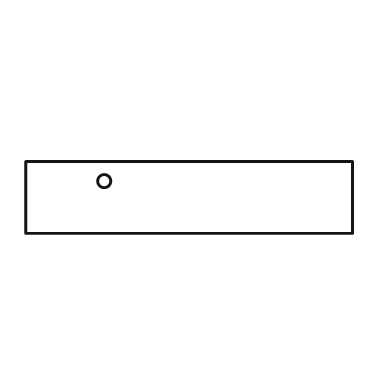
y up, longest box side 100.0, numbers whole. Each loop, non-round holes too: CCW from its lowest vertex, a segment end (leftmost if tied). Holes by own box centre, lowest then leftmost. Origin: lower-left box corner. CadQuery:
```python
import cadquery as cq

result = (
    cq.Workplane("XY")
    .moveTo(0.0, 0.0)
    .lineTo(100.0, 0.0)
    .lineTo(100.0, 22.0)
    .lineTo(0.0, 22.0)
    .close()
    .moveTo(24.0, 16.0)
    .circle(2.0)
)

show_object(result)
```